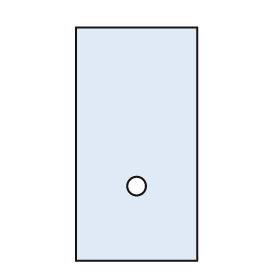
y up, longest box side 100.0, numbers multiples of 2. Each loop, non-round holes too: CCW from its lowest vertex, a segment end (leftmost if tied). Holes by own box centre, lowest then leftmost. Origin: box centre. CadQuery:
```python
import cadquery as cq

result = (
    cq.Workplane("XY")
    .moveTo(-26.0, -50.0)
    .lineTo(26.0, -50.0)
    .lineTo(26.0, 50.0)
    .lineTo(-26.0, 50.0)
    .close()
    .moveTo(0.0, -18.0)
    .circle(4.0)
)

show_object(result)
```